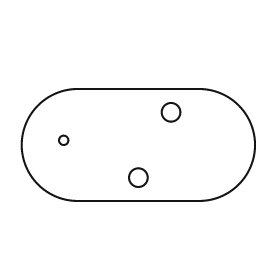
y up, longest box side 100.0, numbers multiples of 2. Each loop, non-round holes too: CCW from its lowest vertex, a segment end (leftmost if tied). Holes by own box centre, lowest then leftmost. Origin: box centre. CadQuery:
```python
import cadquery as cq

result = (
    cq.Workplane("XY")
    .moveTo(-26.0, -24.0)
    .lineTo(26.0, -24.0)
    .threePointArc((50.0, 0.0), (26.0, 24.0))
    .lineTo(-26.0, 24.0)
    .threePointArc((-50.0, 0.0), (-26.0, -24.0))
    .close()
    .moveTo(0.0, -14.0)
    .circle(4.0)
    .moveTo(-32.0, 2.0)
    .circle(2.0)
    .moveTo(14.0, 14.0)
    .circle(4.0)
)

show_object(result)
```